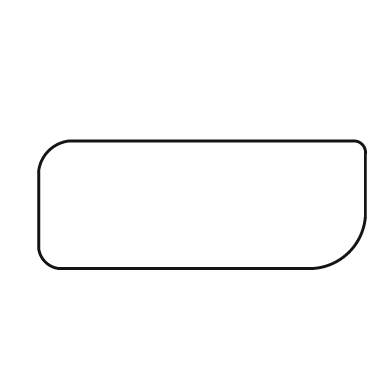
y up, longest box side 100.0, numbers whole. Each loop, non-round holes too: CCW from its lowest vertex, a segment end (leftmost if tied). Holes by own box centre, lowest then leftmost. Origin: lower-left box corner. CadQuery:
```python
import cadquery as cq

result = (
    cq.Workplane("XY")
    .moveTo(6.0, 0.0)
    .lineTo(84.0, 0.0)
    .threePointArc((95.0, 5.0), (100.0, 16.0))
    .lineTo(100.0, 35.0)
    .threePointArc((99.0, 38.0), (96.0, 39.0))
    .lineTo(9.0, 39.0)
    .threePointArc((3.0, 36.0), (0.0, 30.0))
    .lineTo(0.0, 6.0)
    .threePointArc((2.0, 2.0), (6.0, 0.0))
    .close()
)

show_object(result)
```